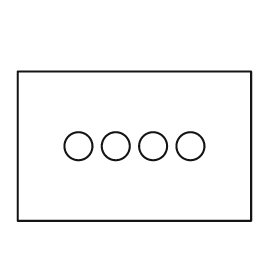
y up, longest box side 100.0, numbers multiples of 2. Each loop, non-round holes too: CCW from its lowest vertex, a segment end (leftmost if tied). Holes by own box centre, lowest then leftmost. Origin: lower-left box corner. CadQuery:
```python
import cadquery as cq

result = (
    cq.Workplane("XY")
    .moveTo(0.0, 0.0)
    .lineTo(100.0, 0.0)
    .lineTo(100.0, 64.0)
    .lineTo(0.0, 64.0)
    .close()
    .moveTo(26.0, 32.0)
    .circle(6.0)
    .moveTo(42.0, 32.0)
    .circle(6.0)
    .moveTo(58.0, 32.0)
    .circle(6.0)
    .moveTo(74.0, 32.0)
    .circle(6.0)
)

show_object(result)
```